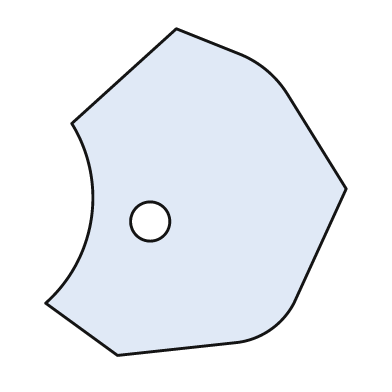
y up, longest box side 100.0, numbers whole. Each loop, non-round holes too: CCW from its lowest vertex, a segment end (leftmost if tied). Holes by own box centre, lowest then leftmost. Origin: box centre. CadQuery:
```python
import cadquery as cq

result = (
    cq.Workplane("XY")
    .moveTo(-24.0, -50.0)
    .lineTo(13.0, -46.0)
    .threePointArc((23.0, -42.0), (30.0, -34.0))
    .lineTo(46.0, 1.0)
    .lineTo(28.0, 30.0)
    .threePointArc((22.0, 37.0), (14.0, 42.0))
    .lineTo(-6.0, 50.0)
    .lineTo(-38.0, 21.0)
    .threePointArc((-32.0, -8.0), (-46.0, -34.0))
    .close()
    .moveTo(-14.0, -9.0)
    .circle(6.0)
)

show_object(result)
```